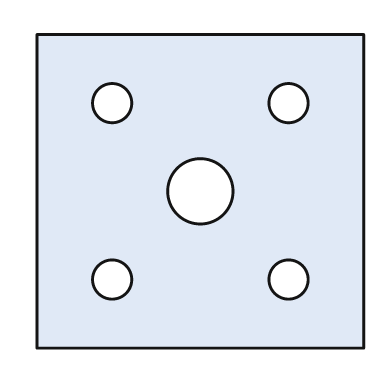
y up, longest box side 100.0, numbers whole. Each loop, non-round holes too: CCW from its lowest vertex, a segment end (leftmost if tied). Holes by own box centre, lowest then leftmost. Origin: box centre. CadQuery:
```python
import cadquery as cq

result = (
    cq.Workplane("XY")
    .moveTo(-50.0, -48.0)
    .lineTo(50.0, -48.0)
    .lineTo(50.0, 48.0)
    .lineTo(-50.0, 48.0)
    .close()
    .moveTo(-27.0, -27.0)
    .circle(6.0)
    .moveTo(27.0, -27.0)
    .circle(6.0)
    .moveTo(0.0, 0.0)
    .circle(10.0)
    .moveTo(-27.0, 27.0)
    .circle(6.0)
    .moveTo(27.0, 27.0)
    .circle(6.0)
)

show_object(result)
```